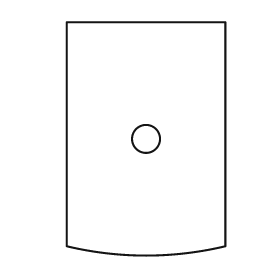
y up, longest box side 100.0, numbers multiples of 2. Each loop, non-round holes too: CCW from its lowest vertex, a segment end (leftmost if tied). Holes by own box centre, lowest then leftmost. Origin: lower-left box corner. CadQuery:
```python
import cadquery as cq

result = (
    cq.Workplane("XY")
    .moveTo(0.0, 4.0)
    .threePointArc((34.0, 0.0), (68.0, 4.0))
    .lineTo(68.0, 100.0)
    .lineTo(0.0, 100.0)
    .close()
    .moveTo(34.0, 50.0)
    .circle(6.0)
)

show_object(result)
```